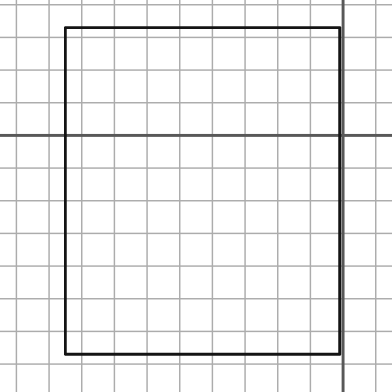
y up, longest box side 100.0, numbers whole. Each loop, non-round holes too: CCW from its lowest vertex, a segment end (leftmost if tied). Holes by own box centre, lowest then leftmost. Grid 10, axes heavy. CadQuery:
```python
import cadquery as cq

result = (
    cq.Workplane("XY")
    .moveTo(-85.0, -67.0)
    .lineTo(-1.0, -67.0)
    .lineTo(-1.0, 33.0)
    .lineTo(-85.0, 33.0)
    .close()
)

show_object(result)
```